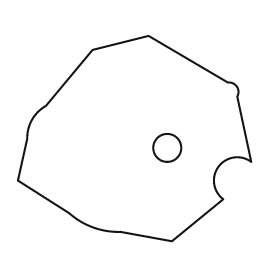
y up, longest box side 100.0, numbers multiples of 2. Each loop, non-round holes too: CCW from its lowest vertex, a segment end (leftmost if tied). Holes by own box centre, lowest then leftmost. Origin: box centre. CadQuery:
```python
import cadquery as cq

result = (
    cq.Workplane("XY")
    .moveTo(16.0, -44.0)
    .lineTo(38.0, -26.0)
    .threePointArc((36.0, -12.0), (50.0, -10.0))
    .lineTo(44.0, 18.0)
    .threePointArc((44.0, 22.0), (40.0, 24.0))
    .lineTo(6.0, 44.0)
    .lineTo(-18.0, 38.0)
    .lineTo(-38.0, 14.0)
    .threePointArc((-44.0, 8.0), (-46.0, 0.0))
    .lineTo(-50.0, -18.0)
    .lineTo(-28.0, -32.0)
    .threePointArc((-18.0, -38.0), (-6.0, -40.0))
    .close()
    .moveTo(14.0, -4.0)
    .circle(6.0)
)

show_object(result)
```